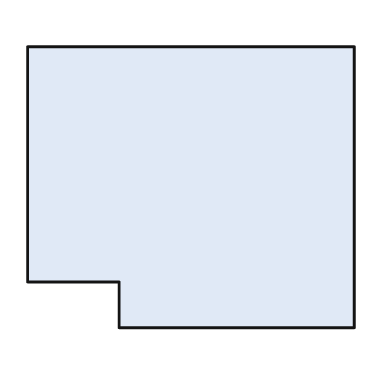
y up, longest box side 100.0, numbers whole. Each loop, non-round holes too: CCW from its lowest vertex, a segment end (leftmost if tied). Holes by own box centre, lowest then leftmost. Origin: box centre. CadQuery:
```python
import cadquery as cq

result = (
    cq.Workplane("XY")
    .moveTo(-22.0, -43.0)
    .lineTo(50.0, -43.0)
    .lineTo(50.0, 43.0)
    .lineTo(-50.0, 43.0)
    .lineTo(-50.0, -29.0)
    .lineTo(-22.0, -29.0)
    .close()
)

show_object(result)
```